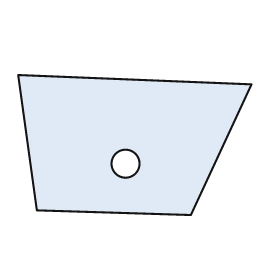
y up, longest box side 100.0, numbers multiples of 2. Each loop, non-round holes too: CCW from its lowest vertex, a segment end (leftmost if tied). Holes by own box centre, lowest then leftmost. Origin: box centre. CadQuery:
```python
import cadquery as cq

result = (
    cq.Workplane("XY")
    .moveTo(24.0, -30.0)
    .lineTo(50.0, 26.0)
    .lineTo(-50.0, 30.0)
    .lineTo(-42.0, -28.0)
    .close()
    .moveTo(-4.0, -8.0)
    .circle(6.0)
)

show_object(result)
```